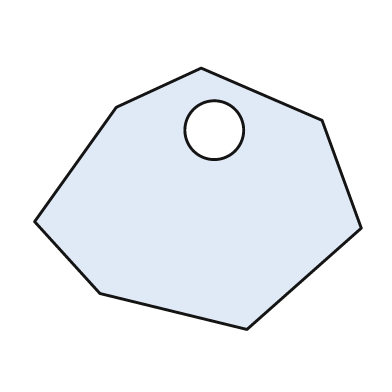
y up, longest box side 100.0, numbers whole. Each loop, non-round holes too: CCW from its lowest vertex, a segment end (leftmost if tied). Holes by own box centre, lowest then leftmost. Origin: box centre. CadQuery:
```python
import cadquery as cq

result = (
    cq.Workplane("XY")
    .moveTo(15.0, -40.0)
    .lineTo(50.0, -9.0)
    .lineTo(38.0, 24.0)
    .lineTo(1.0, 40.0)
    .lineTo(-25.0, 28.0)
    .lineTo(-50.0, -7.0)
    .lineTo(-30.0, -29.0)
    .close()
    .moveTo(5.0, 21.0)
    .circle(9.0)
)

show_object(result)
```